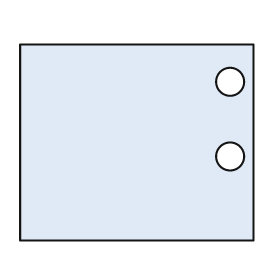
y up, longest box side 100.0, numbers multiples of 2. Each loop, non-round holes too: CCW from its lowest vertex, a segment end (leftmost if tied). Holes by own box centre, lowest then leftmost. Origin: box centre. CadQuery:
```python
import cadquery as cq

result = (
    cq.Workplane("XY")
    .moveTo(-50.0, -42.0)
    .lineTo(50.0, -42.0)
    .lineTo(50.0, 42.0)
    .lineTo(-50.0, 42.0)
    .close()
    .moveTo(40.0, -6.0)
    .circle(6.0)
    .moveTo(40.0, 26.0)
    .circle(6.0)
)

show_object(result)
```